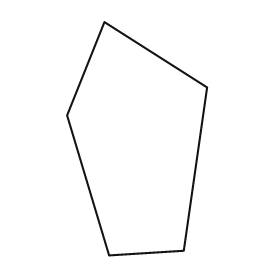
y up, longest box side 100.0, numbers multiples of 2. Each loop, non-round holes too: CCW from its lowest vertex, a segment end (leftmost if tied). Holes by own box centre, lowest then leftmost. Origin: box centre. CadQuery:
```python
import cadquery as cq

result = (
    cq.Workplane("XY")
    .moveTo(-12.0, -50.0)
    .lineTo(20.0, -48.0)
    .lineTo(30.0, 22.0)
    .lineTo(-14.0, 50.0)
    .lineTo(-30.0, 10.0)
    .close()
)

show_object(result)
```